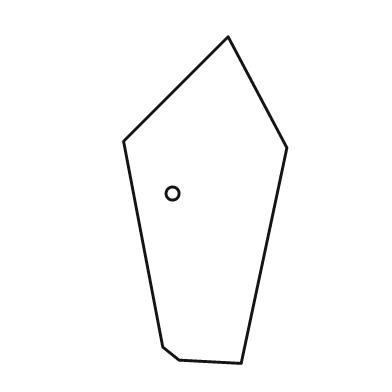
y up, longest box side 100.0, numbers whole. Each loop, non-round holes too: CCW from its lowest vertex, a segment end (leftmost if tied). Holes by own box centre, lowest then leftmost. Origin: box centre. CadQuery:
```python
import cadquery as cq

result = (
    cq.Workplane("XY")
    .moveTo(11.0, -50.0)
    .lineTo(25.0, 16.0)
    .lineTo(7.0, 50.0)
    .lineTo(-25.0, 18.0)
    .lineTo(-13.0, -45.0)
    .lineTo(-8.0, -49.0)
    .close()
    .moveTo(-10.0, 2.0)
    .circle(2.0)
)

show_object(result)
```